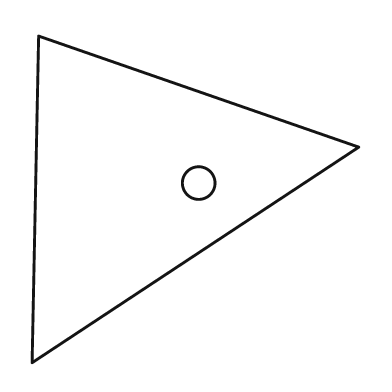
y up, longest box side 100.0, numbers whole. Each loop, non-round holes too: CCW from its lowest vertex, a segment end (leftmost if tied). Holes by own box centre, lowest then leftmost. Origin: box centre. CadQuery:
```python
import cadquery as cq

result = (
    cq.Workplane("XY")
    .moveTo(-50.0, -50.0)
    .lineTo(50.0, 16.0)
    .lineTo(-48.0, 50.0)
    .close()
    .moveTo(1.0, 5.0)
    .circle(5.0)
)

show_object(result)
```